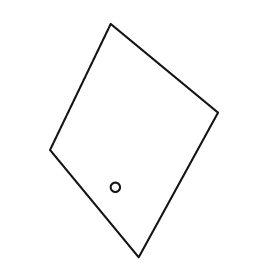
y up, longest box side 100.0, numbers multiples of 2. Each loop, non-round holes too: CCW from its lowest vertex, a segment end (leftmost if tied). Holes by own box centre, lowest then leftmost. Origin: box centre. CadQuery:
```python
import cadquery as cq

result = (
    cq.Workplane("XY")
    .moveTo(2.0, -50.0)
    .lineTo(36.0, 12.0)
    .lineTo(-10.0, 50.0)
    .lineTo(-36.0, -4.0)
    .close()
    .moveTo(-8.0, -20.0)
    .circle(2.0)
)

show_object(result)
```